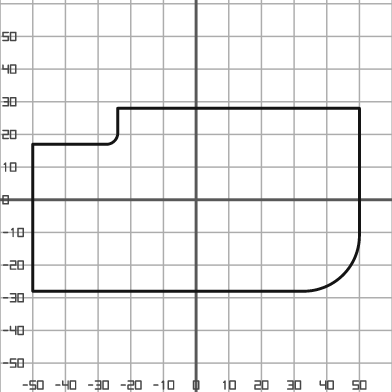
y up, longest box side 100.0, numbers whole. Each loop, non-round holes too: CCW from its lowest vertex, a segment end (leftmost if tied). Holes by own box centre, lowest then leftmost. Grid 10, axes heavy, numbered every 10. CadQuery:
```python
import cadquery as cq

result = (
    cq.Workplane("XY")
    .moveTo(-50.0, -28.0)
    .lineTo(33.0, -28.0)
    .threePointArc((45.0, -23.0), (50.0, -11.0))
    .lineTo(50.0, 28.0)
    .lineTo(-24.0, 28.0)
    .lineTo(-24.0, 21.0)
    .threePointArc((-25.0, 18.0), (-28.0, 17.0))
    .lineTo(-50.0, 17.0)
    .close()
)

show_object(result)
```